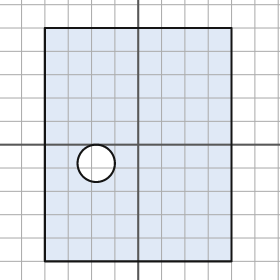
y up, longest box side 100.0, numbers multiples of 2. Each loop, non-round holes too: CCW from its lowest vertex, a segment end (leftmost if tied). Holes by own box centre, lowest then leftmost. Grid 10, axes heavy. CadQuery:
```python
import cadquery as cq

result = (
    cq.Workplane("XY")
    .moveTo(-40.0, -50.0)
    .lineTo(40.0, -50.0)
    .lineTo(40.0, 50.0)
    .lineTo(-40.0, 50.0)
    .close()
    .moveTo(-18.0, -8.0)
    .circle(8.0)
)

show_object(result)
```